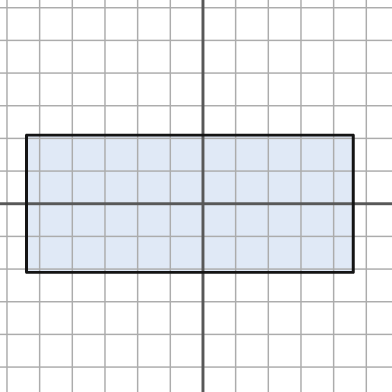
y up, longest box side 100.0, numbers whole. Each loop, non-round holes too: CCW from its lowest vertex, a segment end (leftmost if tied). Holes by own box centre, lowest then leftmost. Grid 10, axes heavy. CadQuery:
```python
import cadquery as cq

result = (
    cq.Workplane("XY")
    .moveTo(-54.0, -21.0)
    .lineTo(46.0, -21.0)
    .lineTo(46.0, 21.0)
    .lineTo(-54.0, 21.0)
    .close()
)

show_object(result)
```